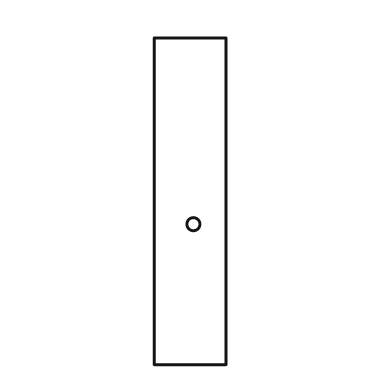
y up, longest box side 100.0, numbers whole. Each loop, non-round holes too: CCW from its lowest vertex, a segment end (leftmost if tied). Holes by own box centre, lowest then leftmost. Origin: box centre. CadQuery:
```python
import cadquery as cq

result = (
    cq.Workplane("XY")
    .moveTo(-11.0, -50.0)
    .lineTo(11.0, -50.0)
    .lineTo(11.0, 50.0)
    .lineTo(-11.0, 50.0)
    .close()
    .moveTo(1.0, -7.0)
    .circle(2.0)
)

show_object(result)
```